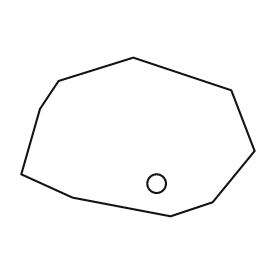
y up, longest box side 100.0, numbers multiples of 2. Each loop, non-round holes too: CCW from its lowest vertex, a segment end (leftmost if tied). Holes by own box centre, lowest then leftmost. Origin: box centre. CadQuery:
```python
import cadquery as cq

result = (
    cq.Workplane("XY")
    .moveTo(14.0, -34.0)
    .lineTo(32.0, -28.0)
    .lineTo(50.0, -6.0)
    .lineTo(40.0, 20.0)
    .lineTo(-2.0, 34.0)
    .lineTo(-34.0, 24.0)
    .lineTo(-42.0, 12.0)
    .lineTo(-50.0, -16.0)
    .lineTo(-28.0, -26.0)
    .close()
    .moveTo(8.0, -20.0)
    .circle(4.0)
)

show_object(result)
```